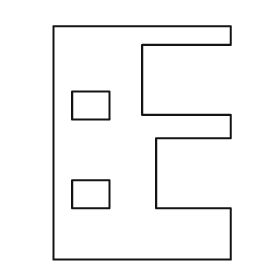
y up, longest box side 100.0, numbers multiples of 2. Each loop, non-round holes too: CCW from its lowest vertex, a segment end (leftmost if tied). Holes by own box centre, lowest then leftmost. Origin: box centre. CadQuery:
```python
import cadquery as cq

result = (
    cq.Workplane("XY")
    .moveTo(-38.0, -50.0)
    .lineTo(38.0, -50.0)
    .lineTo(38.0, -28.0)
    .lineTo(6.0, -28.0)
    .lineTo(6.0, 2.0)
    .lineTo(38.0, 2.0)
    .lineTo(38.0, 12.0)
    .lineTo(0.0, 12.0)
    .lineTo(0.0, 42.0)
    .lineTo(38.0, 42.0)
    .lineTo(38.0, 50.0)
    .lineTo(-38.0, 50.0)
    .close()
    .moveTo(-30.0, -28.0)
    .lineTo(-14.0, -28.0)
    .lineTo(-14.0, -16.0)
    .lineTo(-30.0, -16.0)
    .close()
    .moveTo(-30.0, 10.0)
    .lineTo(-14.0, 10.0)
    .lineTo(-14.0, 22.0)
    .lineTo(-30.0, 22.0)
    .close()
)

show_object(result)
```